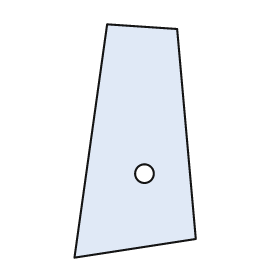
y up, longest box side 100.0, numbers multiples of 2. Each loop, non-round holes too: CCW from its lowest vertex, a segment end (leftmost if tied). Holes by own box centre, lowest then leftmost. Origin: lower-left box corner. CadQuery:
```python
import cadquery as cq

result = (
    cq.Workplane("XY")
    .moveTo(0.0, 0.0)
    .lineTo(52.0, 8.0)
    .lineTo(44.0, 98.0)
    .lineTo(14.0, 100.0)
    .close()
    .moveTo(30.0, 36.0)
    .circle(4.0)
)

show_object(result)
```